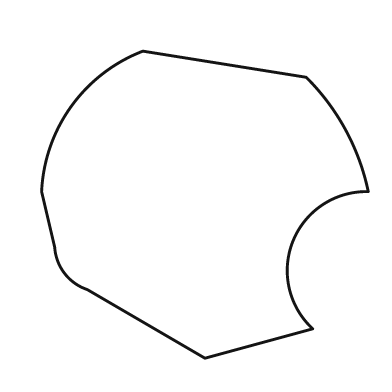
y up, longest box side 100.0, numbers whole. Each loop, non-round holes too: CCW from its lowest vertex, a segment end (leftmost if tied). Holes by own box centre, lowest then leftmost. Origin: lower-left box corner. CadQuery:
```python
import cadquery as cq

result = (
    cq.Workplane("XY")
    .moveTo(50.0, 0.0)
    .lineTo(83.0, 9.0)
    .threePointArc((77.0, 36.0), (100.0, 51.0))
    .threePointArc((93.0, 70.0), (81.0, 86.0))
    .lineTo(31.0, 94.0)
    .threePointArc((9.0, 77.0), (0.0, 51.0))
    .lineTo(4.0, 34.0)
    .threePointArc((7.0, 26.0), (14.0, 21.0))
    .close()
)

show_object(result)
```